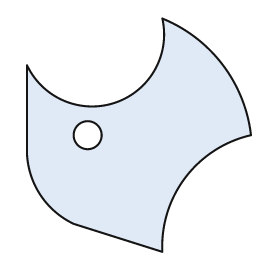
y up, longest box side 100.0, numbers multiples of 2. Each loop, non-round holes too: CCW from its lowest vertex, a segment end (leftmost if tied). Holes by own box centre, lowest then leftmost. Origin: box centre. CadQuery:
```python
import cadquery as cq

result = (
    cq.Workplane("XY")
    .moveTo(10.0, -50.0)
    .threePointArc((20.0, -18.0), (48.0, 0.0))
    .threePointArc((36.0, 30.0), (10.0, 50.0))
    .threePointArc((-10.0, 14.0), (-48.0, 30.0))
    .lineTo(-48.0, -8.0)
    .threePointArc((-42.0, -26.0), (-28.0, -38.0))
    .close()
    .moveTo(-22.0, 0.0)
    .circle(6.0)
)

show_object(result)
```